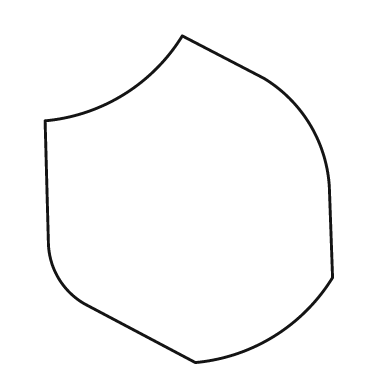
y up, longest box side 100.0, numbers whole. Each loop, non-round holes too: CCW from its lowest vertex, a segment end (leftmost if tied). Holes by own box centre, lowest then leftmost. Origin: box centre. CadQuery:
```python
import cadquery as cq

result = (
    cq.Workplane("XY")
    .moveTo(2.0, -50.0)
    .threePointArc((26.0, -42.0), (44.0, -24.0))
    .lineTo(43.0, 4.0)
    .threePointArc((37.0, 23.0), (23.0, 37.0))
    .lineTo(-2.0, 50.0)
    .threePointArc((-20.0, 32.0), (-44.0, 24.0))
    .lineTo(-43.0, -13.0)
    .threePointArc((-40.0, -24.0), (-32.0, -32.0))
    .close()
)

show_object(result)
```